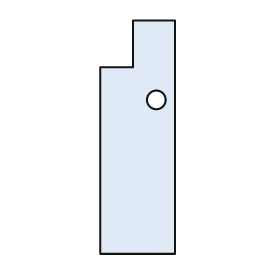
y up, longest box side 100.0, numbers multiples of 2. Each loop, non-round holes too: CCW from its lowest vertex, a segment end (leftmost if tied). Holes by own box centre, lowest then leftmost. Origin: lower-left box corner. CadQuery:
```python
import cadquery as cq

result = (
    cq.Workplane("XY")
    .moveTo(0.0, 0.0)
    .lineTo(32.0, 0.0)
    .lineTo(32.0, 100.0)
    .lineTo(14.0, 100.0)
    .lineTo(14.0, 80.0)
    .lineTo(0.0, 80.0)
    .close()
    .moveTo(24.0, 66.0)
    .circle(4.0)
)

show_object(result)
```